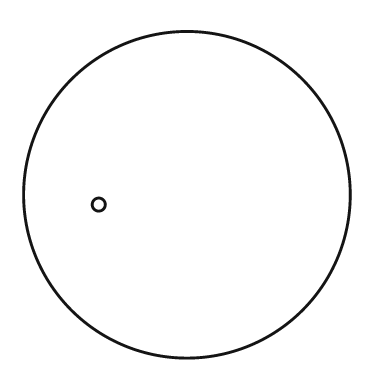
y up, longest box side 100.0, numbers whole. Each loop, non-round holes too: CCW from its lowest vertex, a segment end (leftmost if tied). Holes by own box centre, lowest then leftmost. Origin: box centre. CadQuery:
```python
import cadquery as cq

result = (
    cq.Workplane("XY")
    .moveTo(0.0, 0.0)
    .circle(50.0)
    .moveTo(-27.0, -3.0)
    .circle(2.0)
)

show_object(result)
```